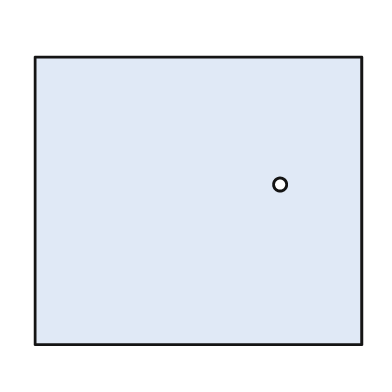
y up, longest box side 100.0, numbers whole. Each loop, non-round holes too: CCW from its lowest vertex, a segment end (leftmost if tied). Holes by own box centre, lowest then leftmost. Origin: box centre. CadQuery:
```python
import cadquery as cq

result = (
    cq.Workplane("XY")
    .moveTo(-50.0, -44.0)
    .lineTo(50.0, -44.0)
    .lineTo(50.0, 44.0)
    .lineTo(-50.0, 44.0)
    .close()
    .moveTo(25.0, 5.0)
    .circle(2.0)
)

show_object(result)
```